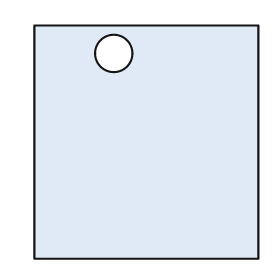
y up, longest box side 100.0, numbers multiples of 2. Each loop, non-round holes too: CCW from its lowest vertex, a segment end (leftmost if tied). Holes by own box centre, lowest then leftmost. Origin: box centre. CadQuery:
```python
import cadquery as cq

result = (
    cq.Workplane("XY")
    .moveTo(-48.0, -50.0)
    .lineTo(48.0, -50.0)
    .lineTo(48.0, 50.0)
    .lineTo(-48.0, 50.0)
    .close()
    .moveTo(-14.0, 38.0)
    .circle(8.0)
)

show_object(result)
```